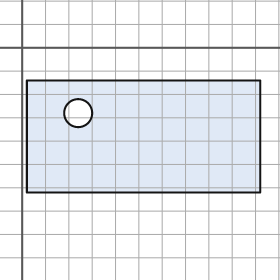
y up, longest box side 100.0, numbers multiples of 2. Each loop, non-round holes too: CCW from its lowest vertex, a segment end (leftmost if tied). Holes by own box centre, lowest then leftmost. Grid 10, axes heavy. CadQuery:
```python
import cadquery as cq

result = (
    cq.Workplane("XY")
    .moveTo(2.0, -62.0)
    .lineTo(102.0, -62.0)
    .lineTo(102.0, -14.0)
    .lineTo(2.0, -14.0)
    .close()
    .moveTo(24.0, -28.0)
    .circle(6.0)
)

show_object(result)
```